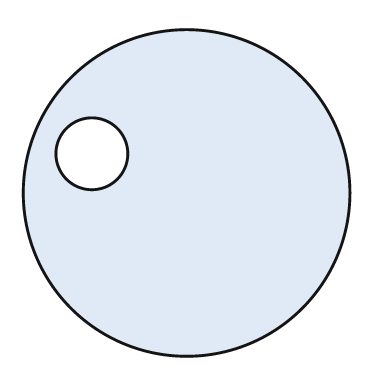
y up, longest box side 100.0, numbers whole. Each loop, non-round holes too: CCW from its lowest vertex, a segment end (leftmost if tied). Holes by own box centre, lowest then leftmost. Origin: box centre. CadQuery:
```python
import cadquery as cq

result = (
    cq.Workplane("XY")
    .moveTo(0.0, 0.0)
    .circle(50.0)
    .moveTo(-29.0, 12.0)
    .circle(11.0)
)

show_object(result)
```